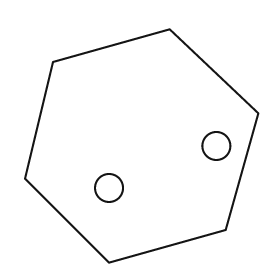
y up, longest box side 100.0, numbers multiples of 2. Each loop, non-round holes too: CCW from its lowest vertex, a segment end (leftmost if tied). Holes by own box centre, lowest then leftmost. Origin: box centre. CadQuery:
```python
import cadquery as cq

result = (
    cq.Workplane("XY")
    .moveTo(-14.0, -50.0)
    .lineTo(36.0, -36.0)
    .lineTo(50.0, 14.0)
    .lineTo(12.0, 50.0)
    .lineTo(-38.0, 36.0)
    .lineTo(-50.0, -14.0)
    .close()
    .moveTo(-14.0, -18.0)
    .circle(6.0)
    .moveTo(32.0, 0.0)
    .circle(6.0)
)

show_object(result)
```